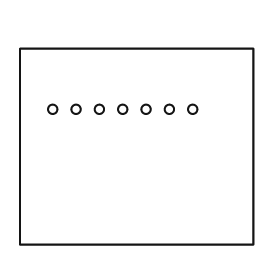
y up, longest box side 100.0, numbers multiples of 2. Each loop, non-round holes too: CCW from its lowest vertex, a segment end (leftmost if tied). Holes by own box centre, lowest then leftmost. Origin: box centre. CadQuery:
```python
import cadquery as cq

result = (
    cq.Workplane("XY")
    .moveTo(-50.0, -42.0)
    .lineTo(50.0, -42.0)
    .lineTo(50.0, 42.0)
    .lineTo(-50.0, 42.0)
    .close()
    .moveTo(-36.0, 16.0)
    .circle(2.0)
    .moveTo(-26.0, 16.0)
    .circle(2.0)
    .moveTo(-16.0, 16.0)
    .circle(2.0)
    .moveTo(-6.0, 16.0)
    .circle(2.0)
    .moveTo(4.0, 16.0)
    .circle(2.0)
    .moveTo(14.0, 16.0)
    .circle(2.0)
    .moveTo(24.0, 16.0)
    .circle(2.0)
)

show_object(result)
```